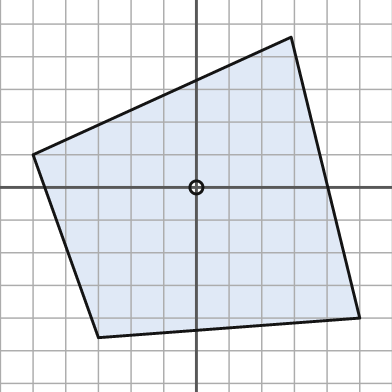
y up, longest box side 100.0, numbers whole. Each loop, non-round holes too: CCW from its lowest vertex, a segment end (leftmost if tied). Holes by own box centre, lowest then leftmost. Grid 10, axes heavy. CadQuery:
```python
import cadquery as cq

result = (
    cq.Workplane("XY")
    .moveTo(-30.0, -46.0)
    .lineTo(50.0, -40.0)
    .lineTo(29.0, 46.0)
    .lineTo(-50.0, 10.0)
    .close()
    .moveTo(0.0, 0.0)
    .circle(2.0)
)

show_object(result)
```